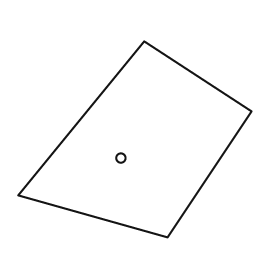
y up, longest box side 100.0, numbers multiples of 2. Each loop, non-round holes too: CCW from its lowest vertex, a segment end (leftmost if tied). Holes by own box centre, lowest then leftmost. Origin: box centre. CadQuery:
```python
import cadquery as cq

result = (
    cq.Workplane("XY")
    .moveTo(14.0, -42.0)
    .lineTo(50.0, 12.0)
    .lineTo(4.0, 42.0)
    .lineTo(-50.0, -24.0)
    .close()
    .moveTo(-6.0, -8.0)
    .circle(2.0)
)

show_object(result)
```